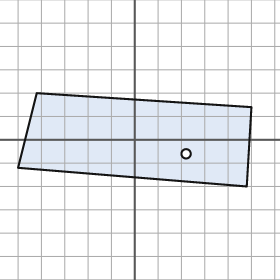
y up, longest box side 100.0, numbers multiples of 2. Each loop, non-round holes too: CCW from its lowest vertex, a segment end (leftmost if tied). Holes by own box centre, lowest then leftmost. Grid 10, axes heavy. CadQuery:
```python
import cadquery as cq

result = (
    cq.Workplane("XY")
    .moveTo(48.0, -20.0)
    .lineTo(50.0, 14.0)
    .lineTo(-42.0, 20.0)
    .lineTo(-50.0, -12.0)
    .close()
    .moveTo(22.0, -6.0)
    .circle(2.0)
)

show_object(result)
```